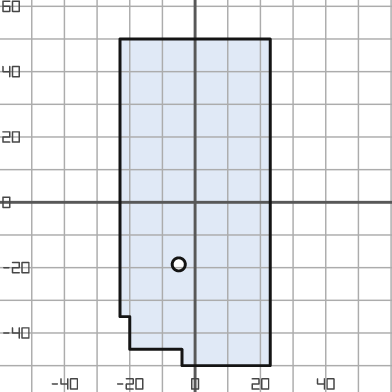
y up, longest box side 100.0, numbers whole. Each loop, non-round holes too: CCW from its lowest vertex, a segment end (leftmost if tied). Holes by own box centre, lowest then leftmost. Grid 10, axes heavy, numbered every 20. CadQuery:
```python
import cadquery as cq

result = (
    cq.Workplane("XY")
    .moveTo(-4.0, -50.0)
    .lineTo(23.0, -50.0)
    .lineTo(23.0, 50.0)
    .lineTo(-23.0, 50.0)
    .lineTo(-23.0, -35.0)
    .lineTo(-20.0, -35.0)
    .lineTo(-20.0, -45.0)
    .lineTo(-4.0, -45.0)
    .close()
    .moveTo(-5.0, -19.0)
    .circle(2.0)
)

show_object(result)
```